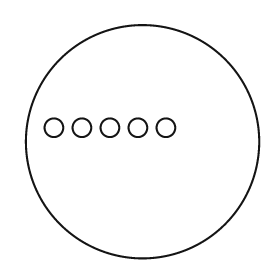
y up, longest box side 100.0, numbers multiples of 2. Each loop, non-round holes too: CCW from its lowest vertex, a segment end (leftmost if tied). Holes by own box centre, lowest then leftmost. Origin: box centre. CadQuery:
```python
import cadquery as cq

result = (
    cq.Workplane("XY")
    .moveTo(0.0, 0.0)
    .circle(50.0)
    .moveTo(-38.0, 6.0)
    .circle(4.0)
    .moveTo(-26.0, 6.0)
    .circle(4.0)
    .moveTo(-14.0, 6.0)
    .circle(4.0)
    .moveTo(-2.0, 6.0)
    .circle(4.0)
    .moveTo(10.0, 6.0)
    .circle(4.0)
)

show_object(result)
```